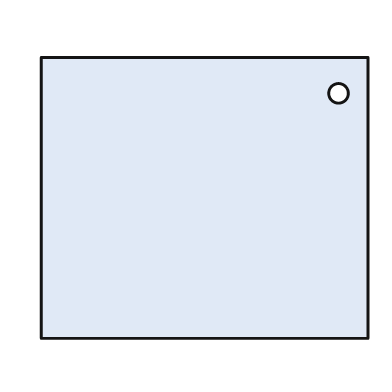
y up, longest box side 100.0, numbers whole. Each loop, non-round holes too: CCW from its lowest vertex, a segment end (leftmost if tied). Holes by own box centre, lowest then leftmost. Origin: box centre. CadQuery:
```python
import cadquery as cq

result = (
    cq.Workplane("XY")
    .moveTo(-50.0, -43.0)
    .lineTo(50.0, -43.0)
    .lineTo(50.0, 43.0)
    .lineTo(-50.0, 43.0)
    .close()
    .moveTo(41.0, 32.0)
    .circle(3.0)
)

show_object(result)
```